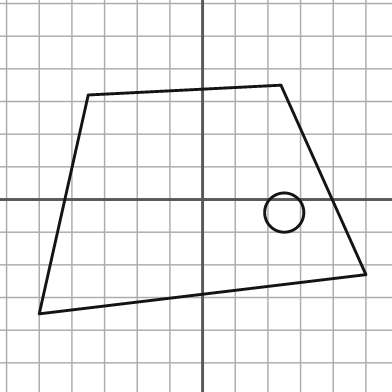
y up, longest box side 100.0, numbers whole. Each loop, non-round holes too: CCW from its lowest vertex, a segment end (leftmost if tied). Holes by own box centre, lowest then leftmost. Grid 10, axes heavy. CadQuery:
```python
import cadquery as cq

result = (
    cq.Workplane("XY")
    .moveTo(-50.0, -35.0)
    .lineTo(50.0, -23.0)
    .lineTo(24.0, 35.0)
    .lineTo(-35.0, 32.0)
    .close()
    .moveTo(25.0, -4.0)
    .circle(6.0)
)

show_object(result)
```